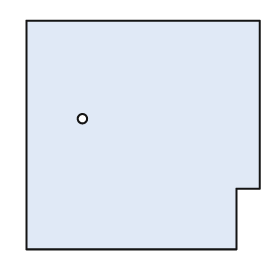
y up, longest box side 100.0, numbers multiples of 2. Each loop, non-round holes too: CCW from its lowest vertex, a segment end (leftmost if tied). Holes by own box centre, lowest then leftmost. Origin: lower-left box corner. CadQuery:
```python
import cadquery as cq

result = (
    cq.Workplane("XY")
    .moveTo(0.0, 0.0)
    .lineTo(90.0, 0.0)
    .lineTo(90.0, 26.0)
    .lineTo(100.0, 26.0)
    .lineTo(100.0, 98.0)
    .lineTo(0.0, 98.0)
    .close()
    .moveTo(24.0, 56.0)
    .circle(2.0)
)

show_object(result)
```